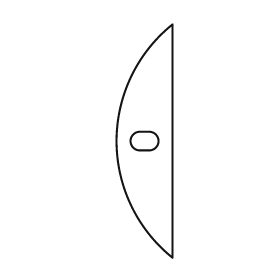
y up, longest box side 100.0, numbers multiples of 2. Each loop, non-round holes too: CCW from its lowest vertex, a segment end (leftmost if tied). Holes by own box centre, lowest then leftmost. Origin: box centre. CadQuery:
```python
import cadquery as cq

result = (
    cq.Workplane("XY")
    .moveTo(12.0, -50.0)
    .lineTo(12.0, 50.0)
    .threePointArc((-12.0, 0.0), (12.0, -50.0))
    .close()
    .moveTo(-2.0, -4.0)
    .lineTo(2.0, -4.0)
    .threePointArc((6.0, 0.0), (2.0, 4.0))
    .lineTo(-2.0, 4.0)
    .threePointArc((-6.0, 0.0), (-2.0, -4.0))
    .close()
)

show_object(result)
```